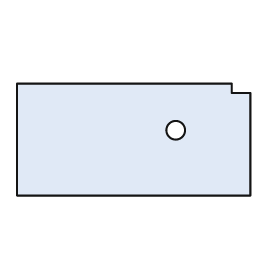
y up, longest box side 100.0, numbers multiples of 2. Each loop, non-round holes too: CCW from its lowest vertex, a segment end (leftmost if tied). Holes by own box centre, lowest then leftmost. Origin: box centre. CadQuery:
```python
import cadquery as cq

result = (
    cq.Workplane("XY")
    .moveTo(-50.0, -24.0)
    .lineTo(50.0, -24.0)
    .lineTo(50.0, 20.0)
    .lineTo(42.0, 20.0)
    .lineTo(42.0, 24.0)
    .lineTo(-50.0, 24.0)
    .close()
    .moveTo(18.0, 4.0)
    .circle(4.0)
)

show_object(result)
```